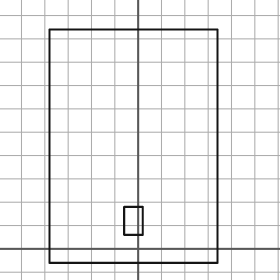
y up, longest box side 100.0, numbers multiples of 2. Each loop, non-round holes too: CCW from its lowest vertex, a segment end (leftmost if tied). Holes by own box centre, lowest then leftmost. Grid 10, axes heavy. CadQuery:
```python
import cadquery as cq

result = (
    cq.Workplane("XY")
    .moveTo(-38.0, -6.0)
    .lineTo(34.0, -6.0)
    .lineTo(34.0, 94.0)
    .lineTo(-38.0, 94.0)
    .close()
    .moveTo(-6.0, 6.0)
    .lineTo(2.0, 6.0)
    .lineTo(2.0, 18.0)
    .lineTo(-6.0, 18.0)
    .close()
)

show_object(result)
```